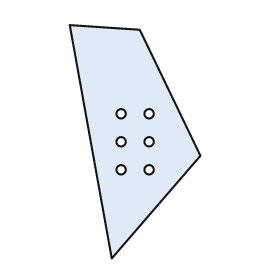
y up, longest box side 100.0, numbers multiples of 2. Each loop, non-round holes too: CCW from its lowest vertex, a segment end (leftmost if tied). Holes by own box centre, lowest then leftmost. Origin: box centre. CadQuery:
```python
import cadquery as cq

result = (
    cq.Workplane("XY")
    .moveTo(-10.0, -50.0)
    .lineTo(28.0, -6.0)
    .lineTo(2.0, 48.0)
    .lineTo(-28.0, 50.0)
    .close()
    .moveTo(-6.0, -12.0)
    .circle(2.0)
    .moveTo(6.0, -12.0)
    .circle(2.0)
    .moveTo(-6.0, 0.0)
    .circle(2.0)
    .moveTo(6.0, 0.0)
    .circle(2.0)
    .moveTo(-6.0, 12.0)
    .circle(2.0)
    .moveTo(6.0, 12.0)
    .circle(2.0)
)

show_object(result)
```